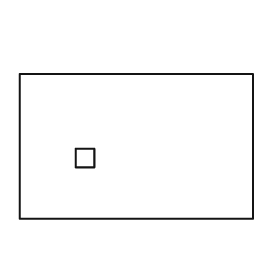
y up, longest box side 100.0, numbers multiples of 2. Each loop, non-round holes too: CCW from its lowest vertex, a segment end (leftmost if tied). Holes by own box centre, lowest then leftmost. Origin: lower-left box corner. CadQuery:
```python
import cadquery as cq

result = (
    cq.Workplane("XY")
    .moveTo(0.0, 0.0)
    .lineTo(100.0, 0.0)
    .lineTo(100.0, 62.0)
    .lineTo(0.0, 62.0)
    .close()
    .moveTo(24.0, 22.0)
    .lineTo(32.0, 22.0)
    .lineTo(32.0, 30.0)
    .lineTo(24.0, 30.0)
    .close()
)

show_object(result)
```